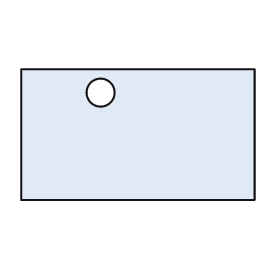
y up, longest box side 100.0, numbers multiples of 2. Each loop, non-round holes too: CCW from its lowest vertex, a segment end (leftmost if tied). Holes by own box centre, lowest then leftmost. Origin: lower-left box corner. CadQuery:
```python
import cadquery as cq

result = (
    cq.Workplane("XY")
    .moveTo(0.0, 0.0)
    .lineTo(100.0, 0.0)
    .lineTo(100.0, 56.0)
    .lineTo(0.0, 56.0)
    .close()
    .moveTo(34.0, 46.0)
    .circle(6.0)
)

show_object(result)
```